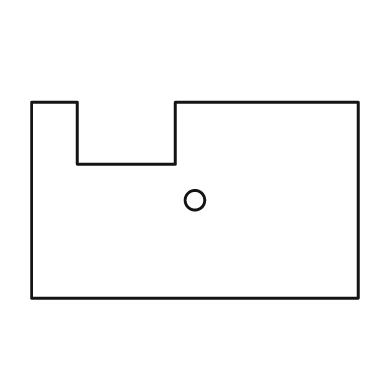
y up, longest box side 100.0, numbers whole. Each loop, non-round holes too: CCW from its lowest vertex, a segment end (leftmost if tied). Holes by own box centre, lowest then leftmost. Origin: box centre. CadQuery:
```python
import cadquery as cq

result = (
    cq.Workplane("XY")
    .moveTo(-50.0, -30.0)
    .lineTo(50.0, -30.0)
    .lineTo(50.0, 30.0)
    .lineTo(-6.0, 30.0)
    .lineTo(-6.0, 11.0)
    .lineTo(-36.0, 11.0)
    .lineTo(-36.0, 30.0)
    .lineTo(-50.0, 30.0)
    .close()
    .moveTo(0.0, 0.0)
    .circle(3.0)
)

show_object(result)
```